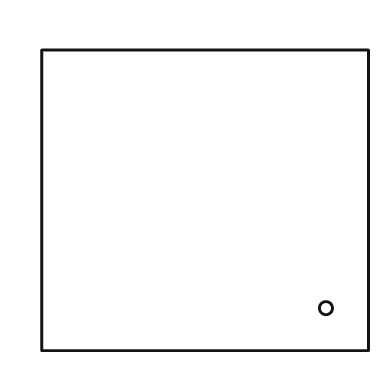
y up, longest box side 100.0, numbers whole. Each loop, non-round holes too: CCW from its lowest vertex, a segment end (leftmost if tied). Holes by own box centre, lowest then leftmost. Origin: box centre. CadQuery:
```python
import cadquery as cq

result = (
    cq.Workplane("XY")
    .moveTo(-50.0, -46.0)
    .lineTo(50.0, -46.0)
    .lineTo(50.0, 46.0)
    .lineTo(-50.0, 46.0)
    .close()
    .moveTo(37.0, -33.0)
    .circle(2.0)
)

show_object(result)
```